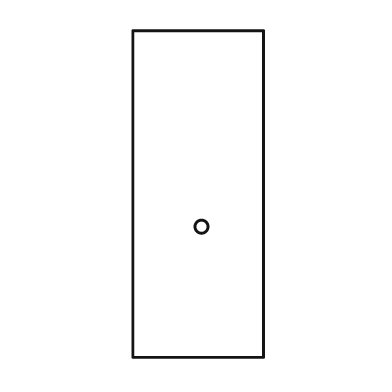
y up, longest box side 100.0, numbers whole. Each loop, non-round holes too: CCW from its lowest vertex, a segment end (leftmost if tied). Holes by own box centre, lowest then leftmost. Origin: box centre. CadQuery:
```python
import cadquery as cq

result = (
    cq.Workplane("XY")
    .moveTo(-20.0, -50.0)
    .lineTo(20.0, -50.0)
    .lineTo(20.0, 50.0)
    .lineTo(-20.0, 50.0)
    .close()
    .moveTo(1.0, -10.0)
    .circle(2.0)
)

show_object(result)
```